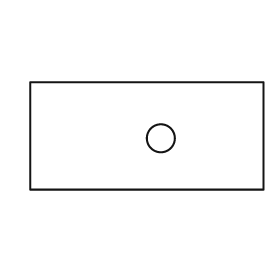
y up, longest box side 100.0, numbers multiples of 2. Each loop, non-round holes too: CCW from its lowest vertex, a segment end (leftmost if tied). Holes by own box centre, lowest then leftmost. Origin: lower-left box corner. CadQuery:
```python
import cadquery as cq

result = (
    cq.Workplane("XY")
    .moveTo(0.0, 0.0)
    .lineTo(100.0, 0.0)
    .lineTo(100.0, 46.0)
    .lineTo(0.0, 46.0)
    .close()
    .moveTo(56.0, 22.0)
    .circle(6.0)
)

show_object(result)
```